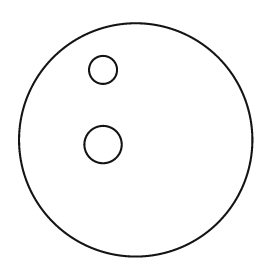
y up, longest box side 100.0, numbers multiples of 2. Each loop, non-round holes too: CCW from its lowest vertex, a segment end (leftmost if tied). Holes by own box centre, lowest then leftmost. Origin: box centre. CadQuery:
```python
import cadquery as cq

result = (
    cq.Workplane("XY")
    .moveTo(0.0, 0.0)
    .circle(50.0)
    .moveTo(-14.0, -2.0)
    .circle(8.0)
    .moveTo(-14.0, 30.0)
    .circle(6.0)
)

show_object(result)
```